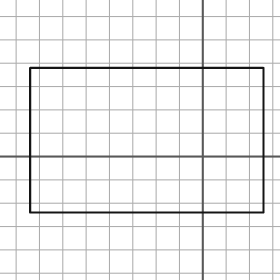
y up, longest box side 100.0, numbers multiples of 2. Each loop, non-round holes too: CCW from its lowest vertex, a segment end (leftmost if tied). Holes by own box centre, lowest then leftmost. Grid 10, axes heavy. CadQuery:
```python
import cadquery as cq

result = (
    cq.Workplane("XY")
    .moveTo(-74.0, -24.0)
    .lineTo(26.0, -24.0)
    .lineTo(26.0, 38.0)
    .lineTo(-74.0, 38.0)
    .close()
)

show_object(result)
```